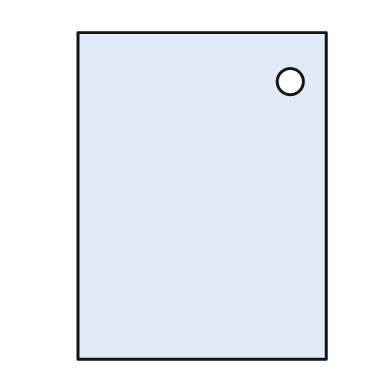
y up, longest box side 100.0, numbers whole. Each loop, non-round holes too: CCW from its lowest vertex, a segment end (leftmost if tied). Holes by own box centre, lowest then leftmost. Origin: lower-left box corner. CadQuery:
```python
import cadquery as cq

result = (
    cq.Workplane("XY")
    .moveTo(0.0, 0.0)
    .lineTo(76.0, 0.0)
    .lineTo(76.0, 100.0)
    .lineTo(0.0, 100.0)
    .close()
    .moveTo(65.0, 85.0)
    .circle(4.0)
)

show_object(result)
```